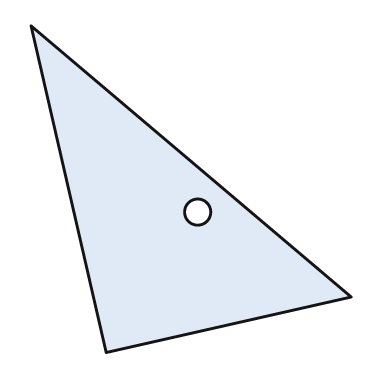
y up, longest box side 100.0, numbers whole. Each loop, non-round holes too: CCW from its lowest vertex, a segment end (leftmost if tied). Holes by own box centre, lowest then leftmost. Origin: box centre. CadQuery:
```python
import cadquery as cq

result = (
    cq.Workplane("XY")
    .moveTo(-26.0, -50.0)
    .lineTo(49.0, -33.0)
    .lineTo(-49.0, 50.0)
    .close()
    .moveTo(2.0, -7.0)
    .circle(4.0)
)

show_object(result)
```